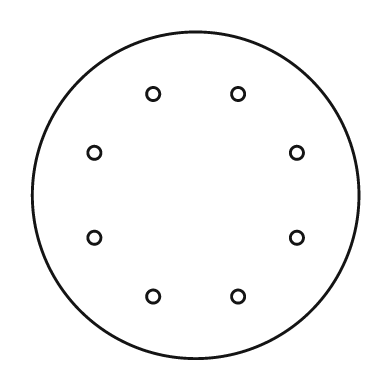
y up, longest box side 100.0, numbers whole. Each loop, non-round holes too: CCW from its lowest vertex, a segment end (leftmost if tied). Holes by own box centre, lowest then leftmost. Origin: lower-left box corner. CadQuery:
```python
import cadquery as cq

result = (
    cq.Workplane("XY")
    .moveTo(50.0, 50.0)
    .circle(50.0)
    .moveTo(37.0, 19.0)
    .circle(2.0)
    .moveTo(63.0, 19.0)
    .circle(2.0)
    .moveTo(19.0, 37.0)
    .circle(2.0)
    .moveTo(81.0, 37.0)
    .circle(2.0)
    .moveTo(19.0, 63.0)
    .circle(2.0)
    .moveTo(81.0, 63.0)
    .circle(2.0)
    .moveTo(37.0, 81.0)
    .circle(2.0)
    .moveTo(63.0, 81.0)
    .circle(2.0)
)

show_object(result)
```